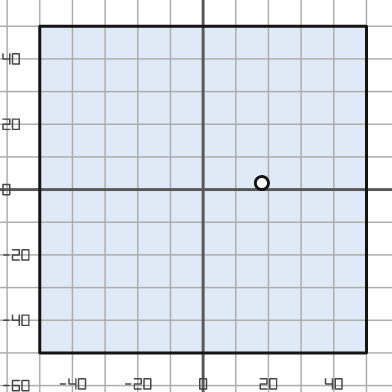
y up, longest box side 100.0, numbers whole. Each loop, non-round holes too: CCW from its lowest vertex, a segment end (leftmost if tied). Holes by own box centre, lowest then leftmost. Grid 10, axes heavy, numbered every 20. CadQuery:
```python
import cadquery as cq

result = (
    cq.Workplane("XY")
    .moveTo(-50.0, -50.0)
    .lineTo(50.0, -50.0)
    .lineTo(50.0, 50.0)
    .lineTo(-50.0, 50.0)
    .close()
    .moveTo(18.0, 2.0)
    .circle(2.0)
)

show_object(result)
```